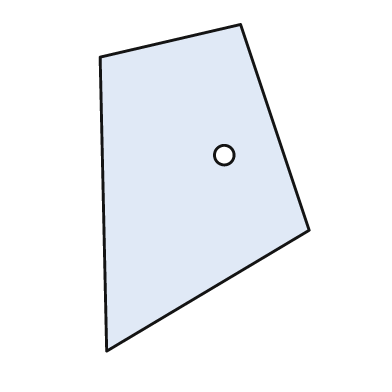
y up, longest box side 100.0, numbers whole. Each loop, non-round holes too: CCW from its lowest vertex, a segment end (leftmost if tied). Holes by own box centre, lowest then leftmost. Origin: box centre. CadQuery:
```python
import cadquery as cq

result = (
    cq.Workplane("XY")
    .moveTo(-30.0, -50.0)
    .lineTo(32.0, -13.0)
    .lineTo(11.0, 50.0)
    .lineTo(-32.0, 40.0)
    .close()
    .moveTo(6.0, 10.0)
    .circle(3.0)
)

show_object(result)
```